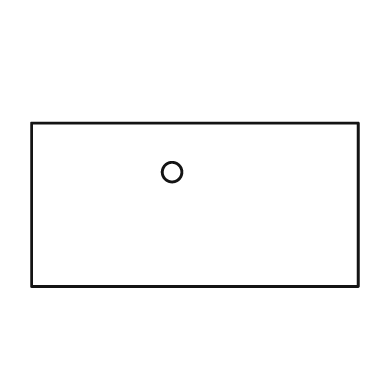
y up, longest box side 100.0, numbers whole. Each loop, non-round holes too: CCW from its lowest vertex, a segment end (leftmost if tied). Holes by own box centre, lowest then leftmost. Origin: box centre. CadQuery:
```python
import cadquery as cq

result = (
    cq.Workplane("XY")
    .moveTo(-50.0, -25.0)
    .lineTo(50.0, -25.0)
    .lineTo(50.0, 25.0)
    .lineTo(-50.0, 25.0)
    .close()
    .moveTo(-7.0, 10.0)
    .circle(3.0)
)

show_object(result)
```